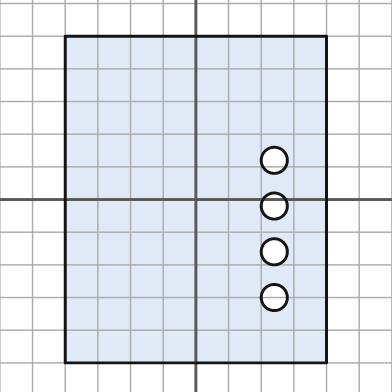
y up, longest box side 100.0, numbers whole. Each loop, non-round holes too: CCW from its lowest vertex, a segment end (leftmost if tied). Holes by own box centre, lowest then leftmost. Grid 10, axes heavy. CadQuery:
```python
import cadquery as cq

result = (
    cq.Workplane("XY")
    .moveTo(-40.0, -50.0)
    .lineTo(40.0, -50.0)
    .lineTo(40.0, 50.0)
    .lineTo(-40.0, 50.0)
    .close()
    .moveTo(24.0, -30.0)
    .circle(4.0)
    .moveTo(24.0, -16.0)
    .circle(4.0)
    .moveTo(24.0, -2.0)
    .circle(4.0)
    .moveTo(24.0, 12.0)
    .circle(4.0)
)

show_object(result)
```